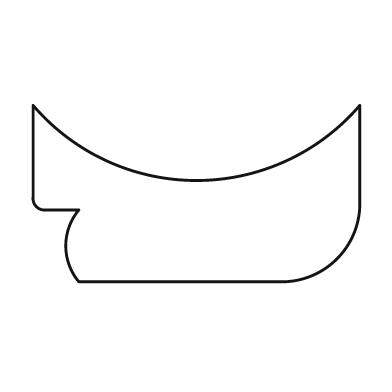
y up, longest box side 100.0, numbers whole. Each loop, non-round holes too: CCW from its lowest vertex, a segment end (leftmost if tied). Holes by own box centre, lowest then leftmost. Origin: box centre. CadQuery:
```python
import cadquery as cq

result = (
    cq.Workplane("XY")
    .moveTo(-36.0, -27.0)
    .lineTo(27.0, -27.0)
    .threePointArc((43.0, -20.0), (50.0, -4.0))
    .lineTo(50.0, 27.0)
    .threePointArc((0.0, 4.0), (-50.0, 27.0))
    .lineTo(-50.0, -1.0)
    .threePointArc((-49.0, -4.0), (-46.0, -5.0))
    .lineTo(-36.0, -5.0)
    .threePointArc((-40.0, -16.0), (-36.0, -27.0))
    .close()
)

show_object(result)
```